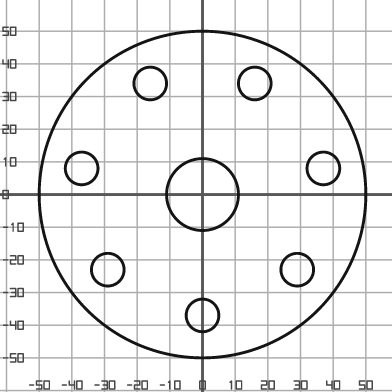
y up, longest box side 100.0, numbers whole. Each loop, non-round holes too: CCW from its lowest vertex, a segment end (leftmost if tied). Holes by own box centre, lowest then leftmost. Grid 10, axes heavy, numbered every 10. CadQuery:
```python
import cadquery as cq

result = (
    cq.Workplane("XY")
    .moveTo(0.0, 0.0)
    .circle(50.0)
    .moveTo(0.0, -37.0)
    .circle(5.0)
    .moveTo(-29.0, -23.0)
    .circle(5.0)
    .moveTo(29.0, -23.0)
    .circle(5.0)
    .moveTo(0.0, 0.0)
    .circle(11.0)
    .moveTo(-37.0, 8.0)
    .circle(5.0)
    .moveTo(37.0, 8.0)
    .circle(5.0)
    .moveTo(-16.0, 34.0)
    .circle(5.0)
    .moveTo(16.0, 34.0)
    .circle(5.0)
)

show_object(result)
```